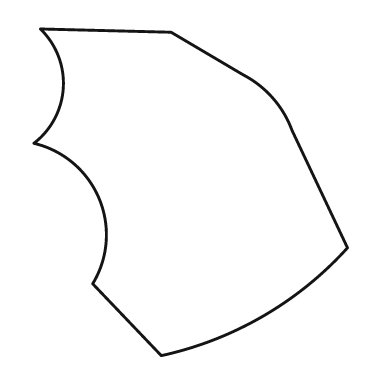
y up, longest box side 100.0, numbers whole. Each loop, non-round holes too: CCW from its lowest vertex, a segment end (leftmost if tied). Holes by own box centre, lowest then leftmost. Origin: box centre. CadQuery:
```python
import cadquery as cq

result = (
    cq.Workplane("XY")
    .moveTo(-9.0, -50.0)
    .threePointArc((22.0, -38.0), (48.0, -17.0))
    .lineTo(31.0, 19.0)
    .threePointArc((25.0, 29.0), (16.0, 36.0))
    .lineTo(-6.0, 49.0)
    .lineTo(-46.0, 50.0)
    .threePointArc((-39.0, 32.0), (-48.0, 15.0))
    .threePointArc((-28.0, -2.0), (-30.0, -28.0))
    .close()
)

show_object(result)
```